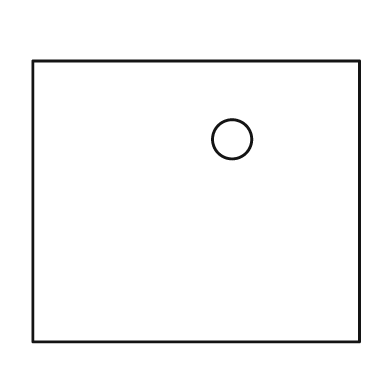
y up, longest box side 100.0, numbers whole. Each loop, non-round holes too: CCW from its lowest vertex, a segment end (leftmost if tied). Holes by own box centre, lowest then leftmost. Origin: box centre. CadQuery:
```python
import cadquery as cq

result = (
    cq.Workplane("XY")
    .moveTo(-50.0, -43.0)
    .lineTo(50.0, -43.0)
    .lineTo(50.0, 43.0)
    .lineTo(-50.0, 43.0)
    .close()
    .moveTo(11.0, 19.0)
    .circle(6.0)
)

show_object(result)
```